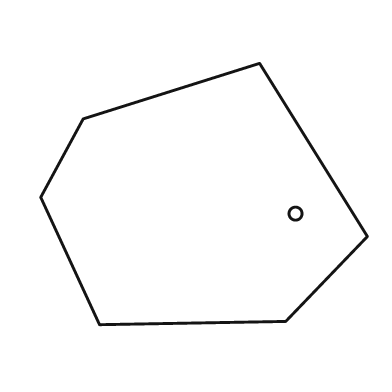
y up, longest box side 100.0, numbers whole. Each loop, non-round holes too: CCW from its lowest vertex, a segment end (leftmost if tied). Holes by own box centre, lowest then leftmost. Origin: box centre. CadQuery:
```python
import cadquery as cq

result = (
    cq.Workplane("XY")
    .moveTo(-32.0, -40.0)
    .lineTo(25.0, -39.0)
    .lineTo(50.0, -13.0)
    .lineTo(17.0, 40.0)
    .lineTo(-37.0, 23.0)
    .lineTo(-50.0, -1.0)
    .close()
    .moveTo(28.0, -6.0)
    .circle(2.0)
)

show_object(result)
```